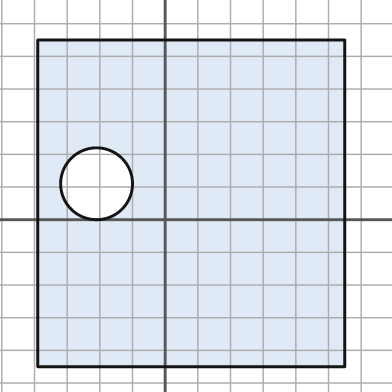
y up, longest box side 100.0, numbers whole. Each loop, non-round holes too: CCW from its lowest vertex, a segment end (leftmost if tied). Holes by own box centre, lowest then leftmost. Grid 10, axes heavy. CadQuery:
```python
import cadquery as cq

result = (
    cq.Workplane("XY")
    .moveTo(-39.0, -45.0)
    .lineTo(55.0, -45.0)
    .lineTo(55.0, 55.0)
    .lineTo(-39.0, 55.0)
    .close()
    .moveTo(-21.0, 11.0)
    .circle(11.0)
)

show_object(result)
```